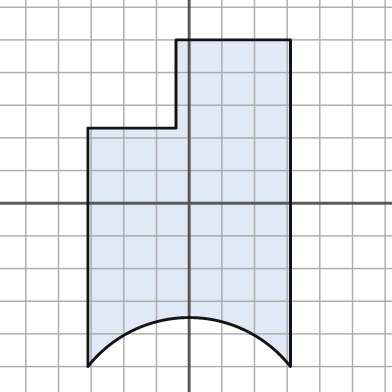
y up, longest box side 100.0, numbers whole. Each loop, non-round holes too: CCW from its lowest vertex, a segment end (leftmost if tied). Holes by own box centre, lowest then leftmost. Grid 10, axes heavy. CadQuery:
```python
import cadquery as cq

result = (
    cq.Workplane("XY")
    .moveTo(-31.0, -50.0)
    .threePointArc((0.0, -35.0), (31.0, -50.0))
    .lineTo(31.0, 50.0)
    .lineTo(-4.0, 50.0)
    .lineTo(-4.0, 23.0)
    .lineTo(-31.0, 23.0)
    .close()
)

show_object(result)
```